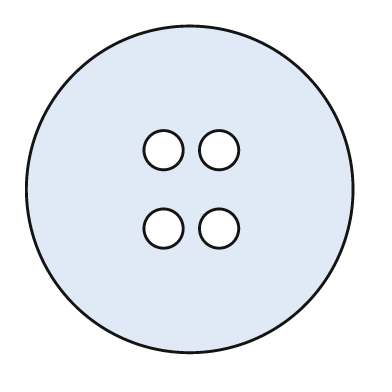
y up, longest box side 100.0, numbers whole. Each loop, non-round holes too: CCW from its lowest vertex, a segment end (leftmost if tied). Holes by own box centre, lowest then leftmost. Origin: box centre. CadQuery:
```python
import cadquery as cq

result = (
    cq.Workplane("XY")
    .moveTo(0.0, 0.0)
    .circle(50.0)
    .moveTo(-8.0, -12.0)
    .circle(6.0)
    .moveTo(9.0, -12.0)
    .circle(6.0)
    .moveTo(-8.0, 12.0)
    .circle(6.0)
    .moveTo(9.0, 12.0)
    .circle(6.0)
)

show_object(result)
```